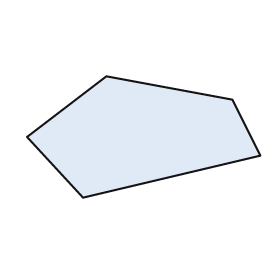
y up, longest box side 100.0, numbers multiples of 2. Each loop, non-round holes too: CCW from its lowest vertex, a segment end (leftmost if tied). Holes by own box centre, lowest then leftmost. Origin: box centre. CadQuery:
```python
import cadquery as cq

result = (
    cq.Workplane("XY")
    .moveTo(-26.0, -26.0)
    .lineTo(50.0, -8.0)
    .lineTo(38.0, 16.0)
    .lineTo(-16.0, 26.0)
    .lineTo(-50.0, 0.0)
    .close()
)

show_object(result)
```